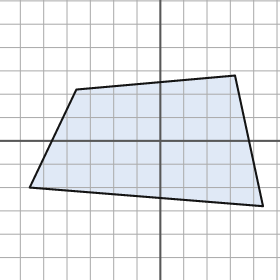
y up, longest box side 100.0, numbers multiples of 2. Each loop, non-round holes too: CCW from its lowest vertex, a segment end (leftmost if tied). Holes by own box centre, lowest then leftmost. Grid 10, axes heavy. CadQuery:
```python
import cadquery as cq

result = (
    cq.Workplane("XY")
    .moveTo(44.0, -28.0)
    .lineTo(32.0, 28.0)
    .lineTo(-36.0, 22.0)
    .lineTo(-56.0, -20.0)
    .close()
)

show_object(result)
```